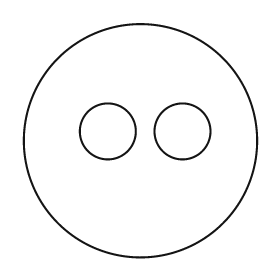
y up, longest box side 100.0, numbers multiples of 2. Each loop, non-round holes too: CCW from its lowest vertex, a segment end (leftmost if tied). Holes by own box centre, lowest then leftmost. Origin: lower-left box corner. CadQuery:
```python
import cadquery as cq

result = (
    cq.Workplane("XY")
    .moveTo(50.0, 50.0)
    .circle(50.0)
    .moveTo(36.0, 54.0)
    .circle(12.0)
    .moveTo(68.0, 54.0)
    .circle(12.0)
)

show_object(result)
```